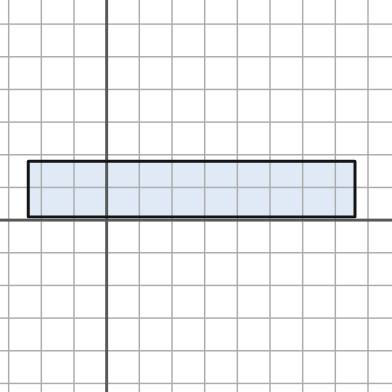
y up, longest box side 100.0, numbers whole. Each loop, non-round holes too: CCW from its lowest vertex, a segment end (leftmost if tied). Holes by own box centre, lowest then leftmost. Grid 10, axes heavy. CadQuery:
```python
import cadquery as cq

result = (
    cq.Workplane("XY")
    .moveTo(-24.0, 1.0)
    .lineTo(76.0, 1.0)
    .lineTo(76.0, 18.0)
    .lineTo(-24.0, 18.0)
    .close()
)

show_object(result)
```